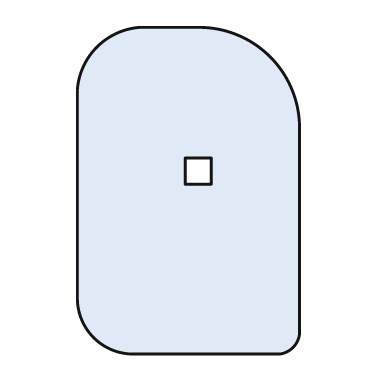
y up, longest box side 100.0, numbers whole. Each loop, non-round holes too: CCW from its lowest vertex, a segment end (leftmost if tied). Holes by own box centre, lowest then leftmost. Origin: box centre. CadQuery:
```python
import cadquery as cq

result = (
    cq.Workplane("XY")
    .moveTo(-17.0, -50.0)
    .lineTo(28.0, -50.0)
    .threePointArc((32.0, -48.0), (34.0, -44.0))
    .lineTo(34.0, 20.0)
    .threePointArc((25.0, 41.0), (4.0, 50.0))
    .lineTo(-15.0, 50.0)
    .threePointArc((-28.0, 44.0), (-34.0, 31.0))
    .lineTo(-34.0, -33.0)
    .threePointArc((-29.0, -45.0), (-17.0, -50.0))
    .close()
    .moveTo(-1.0, 2.0)
    .lineTo(7.0, 2.0)
    .lineTo(7.0, 10.0)
    .lineTo(-1.0, 10.0)
    .close()
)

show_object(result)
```